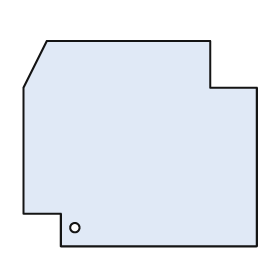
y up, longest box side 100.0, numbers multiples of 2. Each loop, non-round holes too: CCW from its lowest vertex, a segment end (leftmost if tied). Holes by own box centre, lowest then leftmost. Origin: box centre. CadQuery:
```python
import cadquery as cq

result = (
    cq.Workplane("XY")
    .moveTo(-34.0, -44.0)
    .lineTo(50.0, -44.0)
    .lineTo(50.0, 24.0)
    .lineTo(30.0, 24.0)
    .lineTo(30.0, 44.0)
    .lineTo(-40.0, 44.0)
    .lineTo(-50.0, 24.0)
    .lineTo(-50.0, -30.0)
    .lineTo(-34.0, -30.0)
    .close()
    .moveTo(-28.0, -36.0)
    .circle(2.0)
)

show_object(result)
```